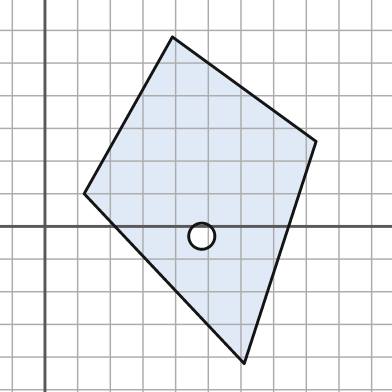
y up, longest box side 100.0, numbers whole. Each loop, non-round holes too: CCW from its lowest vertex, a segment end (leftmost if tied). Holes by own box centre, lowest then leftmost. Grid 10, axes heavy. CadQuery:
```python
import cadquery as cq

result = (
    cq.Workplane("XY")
    .moveTo(61.0, -42.0)
    .lineTo(83.0, 26.0)
    .lineTo(39.0, 58.0)
    .lineTo(12.0, 10.0)
    .close()
    .moveTo(48.0, -3.0)
    .circle(4.0)
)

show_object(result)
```